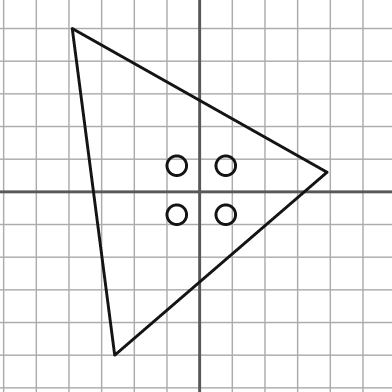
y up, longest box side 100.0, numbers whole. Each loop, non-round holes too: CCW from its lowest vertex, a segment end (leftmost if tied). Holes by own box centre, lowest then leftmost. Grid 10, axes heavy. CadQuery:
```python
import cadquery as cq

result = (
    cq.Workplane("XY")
    .moveTo(-26.0, -50.0)
    .lineTo(39.0, 6.0)
    .lineTo(-39.0, 50.0)
    .close()
    .moveTo(-7.0, -7.0)
    .circle(3.0)
    .moveTo(8.0, -7.0)
    .circle(3.0)
    .moveTo(-7.0, 8.0)
    .circle(3.0)
    .moveTo(8.0, 8.0)
    .circle(3.0)
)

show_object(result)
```